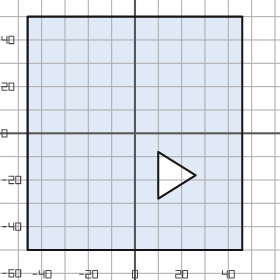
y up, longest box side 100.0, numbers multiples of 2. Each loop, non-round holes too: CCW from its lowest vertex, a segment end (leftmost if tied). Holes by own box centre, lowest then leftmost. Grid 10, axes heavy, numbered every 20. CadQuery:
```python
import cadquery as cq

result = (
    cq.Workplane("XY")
    .moveTo(-46.0, -50.0)
    .lineTo(46.0, -50.0)
    .lineTo(46.0, 50.0)
    .lineTo(-46.0, 50.0)
    .close()
    .moveTo(10.0, -28.0)
    .lineTo(26.0, -18.0)
    .lineTo(10.0, -8.0)
    .close()
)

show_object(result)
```